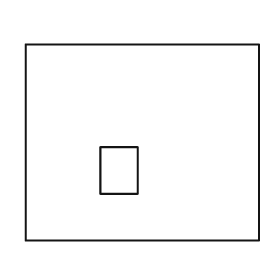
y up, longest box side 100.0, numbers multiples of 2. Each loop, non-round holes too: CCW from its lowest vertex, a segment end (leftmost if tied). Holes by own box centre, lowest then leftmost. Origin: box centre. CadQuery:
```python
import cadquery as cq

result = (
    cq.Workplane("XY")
    .moveTo(-50.0, -42.0)
    .lineTo(50.0, -42.0)
    .lineTo(50.0, 42.0)
    .lineTo(-50.0, 42.0)
    .close()
    .moveTo(-18.0, -22.0)
    .lineTo(-2.0, -22.0)
    .lineTo(-2.0, -2.0)
    .lineTo(-18.0, -2.0)
    .close()
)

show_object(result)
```